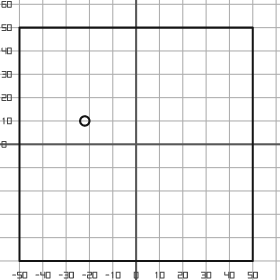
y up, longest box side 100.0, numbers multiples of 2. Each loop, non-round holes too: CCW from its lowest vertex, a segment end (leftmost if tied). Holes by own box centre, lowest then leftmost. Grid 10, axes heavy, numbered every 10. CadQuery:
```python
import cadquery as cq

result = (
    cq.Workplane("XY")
    .moveTo(-50.0, -50.0)
    .lineTo(50.0, -50.0)
    .lineTo(50.0, 50.0)
    .lineTo(-50.0, 50.0)
    .close()
    .moveTo(-22.0, 10.0)
    .circle(2.0)
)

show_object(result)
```